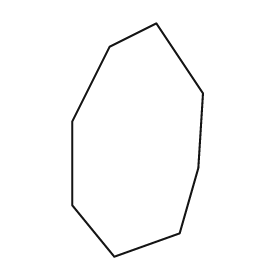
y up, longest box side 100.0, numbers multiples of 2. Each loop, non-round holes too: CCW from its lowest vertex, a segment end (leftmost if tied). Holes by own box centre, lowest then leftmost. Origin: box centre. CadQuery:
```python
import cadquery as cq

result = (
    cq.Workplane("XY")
    .moveTo(-10.0, -50.0)
    .lineTo(18.0, -40.0)
    .lineTo(26.0, -12.0)
    .lineTo(28.0, 20.0)
    .lineTo(8.0, 50.0)
    .lineTo(-12.0, 40.0)
    .lineTo(-28.0, 8.0)
    .lineTo(-28.0, -28.0)
    .close()
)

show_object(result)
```